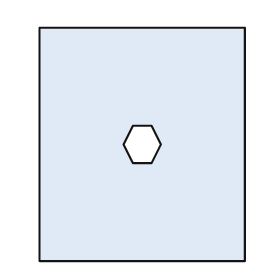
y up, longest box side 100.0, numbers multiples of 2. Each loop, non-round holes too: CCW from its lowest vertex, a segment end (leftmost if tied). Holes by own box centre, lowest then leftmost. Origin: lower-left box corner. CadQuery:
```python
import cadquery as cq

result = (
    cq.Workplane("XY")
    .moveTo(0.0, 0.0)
    .lineTo(88.0, 0.0)
    .lineTo(88.0, 100.0)
    .lineTo(0.0, 100.0)
    .close()
    .moveTo(40.0, 42.0)
    .lineTo(48.0, 42.0)
    .lineTo(52.0, 50.0)
    .lineTo(48.0, 58.0)
    .lineTo(40.0, 58.0)
    .lineTo(36.0, 50.0)
    .close()
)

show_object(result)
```